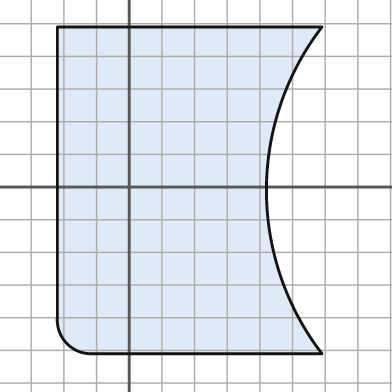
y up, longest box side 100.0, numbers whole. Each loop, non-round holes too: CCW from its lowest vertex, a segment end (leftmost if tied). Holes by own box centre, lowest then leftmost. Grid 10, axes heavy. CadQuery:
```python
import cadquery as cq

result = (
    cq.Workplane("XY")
    .moveTo(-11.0, -51.0)
    .lineTo(59.0, -51.0)
    .threePointArc((42.0, -1.0), (59.0, 49.0))
    .lineTo(-22.0, 49.0)
    .lineTo(-22.0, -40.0)
    .threePointArc((-19.0, -48.0), (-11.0, -51.0))
    .close()
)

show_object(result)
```